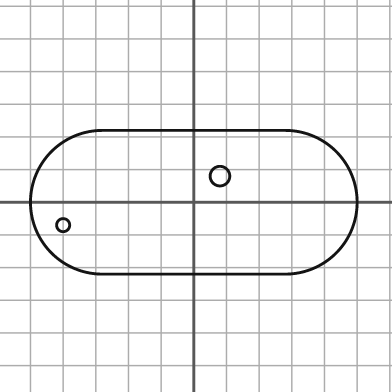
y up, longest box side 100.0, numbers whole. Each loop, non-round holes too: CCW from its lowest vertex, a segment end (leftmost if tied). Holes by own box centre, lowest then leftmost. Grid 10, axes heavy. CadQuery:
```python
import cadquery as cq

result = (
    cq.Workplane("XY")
    .moveTo(-28.0, -22.0)
    .lineTo(28.0, -22.0)
    .threePointArc((50.0, 0.0), (28.0, 22.0))
    .lineTo(-28.0, 22.0)
    .threePointArc((-50.0, 0.0), (-28.0, -22.0))
    .close()
    .moveTo(-40.0, -7.0)
    .circle(2.0)
    .moveTo(8.0, 8.0)
    .circle(3.0)
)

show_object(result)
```